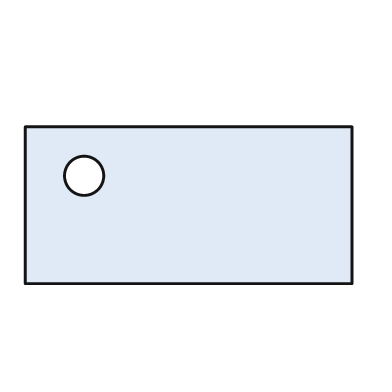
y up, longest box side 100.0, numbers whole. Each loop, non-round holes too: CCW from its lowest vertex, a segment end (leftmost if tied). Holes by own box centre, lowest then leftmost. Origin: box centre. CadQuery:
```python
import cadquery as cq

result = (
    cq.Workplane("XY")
    .moveTo(-50.0, -24.0)
    .lineTo(50.0, -24.0)
    .lineTo(50.0, 24.0)
    .lineTo(-50.0, 24.0)
    .close()
    .moveTo(-32.0, 9.0)
    .circle(6.0)
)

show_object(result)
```